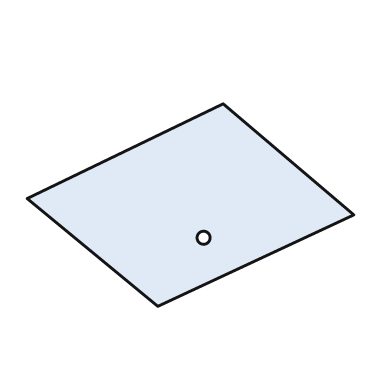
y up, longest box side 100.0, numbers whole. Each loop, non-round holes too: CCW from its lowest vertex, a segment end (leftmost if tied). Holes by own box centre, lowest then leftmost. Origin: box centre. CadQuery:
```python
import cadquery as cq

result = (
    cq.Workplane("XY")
    .moveTo(-10.0, -31.0)
    .lineTo(50.0, -3.0)
    .lineTo(10.0, 31.0)
    .lineTo(-50.0, 2.0)
    .close()
    .moveTo(4.0, -10.0)
    .circle(2.0)
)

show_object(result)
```